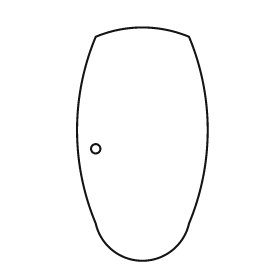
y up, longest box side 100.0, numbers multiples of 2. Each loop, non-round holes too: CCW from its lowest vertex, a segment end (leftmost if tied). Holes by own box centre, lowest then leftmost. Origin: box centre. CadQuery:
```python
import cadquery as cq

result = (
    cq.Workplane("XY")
    .moveTo(-20.0, -34.0)
    .threePointArc((0.0, -50.0), (20.0, -34.0))
    .threePointArc((28.0, 6.0), (20.0, 46.0))
    .threePointArc((0.0, 50.0), (-20.0, 46.0))
    .threePointArc((-28.0, 6.0), (-20.0, -34.0))
    .close()
    .moveTo(-20.0, -2.0)
    .circle(2.0)
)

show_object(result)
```